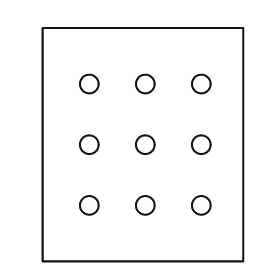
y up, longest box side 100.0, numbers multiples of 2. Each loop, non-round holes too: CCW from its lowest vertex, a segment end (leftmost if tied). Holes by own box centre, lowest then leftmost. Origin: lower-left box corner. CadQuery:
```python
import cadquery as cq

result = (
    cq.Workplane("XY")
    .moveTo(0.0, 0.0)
    .lineTo(86.0, 0.0)
    .lineTo(86.0, 100.0)
    .lineTo(0.0, 100.0)
    .close()
    .moveTo(20.0, 24.0)
    .circle(4.0)
    .moveTo(44.0, 24.0)
    .circle(4.0)
    .moveTo(68.0, 24.0)
    .circle(4.0)
    .moveTo(20.0, 50.0)
    .circle(4.0)
    .moveTo(44.0, 50.0)
    .circle(4.0)
    .moveTo(68.0, 50.0)
    .circle(4.0)
    .moveTo(20.0, 76.0)
    .circle(4.0)
    .moveTo(44.0, 76.0)
    .circle(4.0)
    .moveTo(68.0, 76.0)
    .circle(4.0)
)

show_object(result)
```